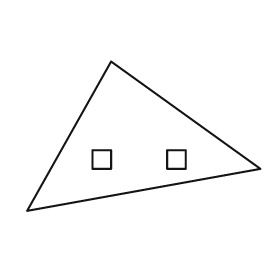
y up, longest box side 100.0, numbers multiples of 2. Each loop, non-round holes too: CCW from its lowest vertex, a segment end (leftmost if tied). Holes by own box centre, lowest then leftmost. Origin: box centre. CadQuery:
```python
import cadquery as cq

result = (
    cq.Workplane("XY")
    .moveTo(-50.0, -32.0)
    .lineTo(50.0, -14.0)
    .lineTo(-14.0, 32.0)
    .close()
    .moveTo(-22.0, -14.0)
    .lineTo(-14.0, -14.0)
    .lineTo(-14.0, -6.0)
    .lineTo(-22.0, -6.0)
    .close()
    .moveTo(10.0, -14.0)
    .lineTo(18.0, -14.0)
    .lineTo(18.0, -6.0)
    .lineTo(10.0, -6.0)
    .close()
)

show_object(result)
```